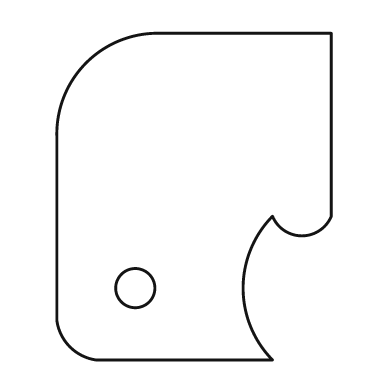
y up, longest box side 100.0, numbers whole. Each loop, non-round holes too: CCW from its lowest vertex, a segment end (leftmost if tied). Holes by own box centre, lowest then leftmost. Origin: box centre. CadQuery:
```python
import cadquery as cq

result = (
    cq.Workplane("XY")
    .moveTo(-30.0, -50.0)
    .lineTo(24.0, -50.0)
    .threePointArc((15.0, -28.0), (24.0, -6.0))
    .threePointArc((33.0, -12.0), (42.0, -6.0))
    .lineTo(42.0, 50.0)
    .lineTo(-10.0, 50.0)
    .threePointArc((-33.0, 41.0), (-42.0, 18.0))
    .lineTo(-42.0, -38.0)
    .threePointArc((-38.0, -46.0), (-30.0, -50.0))
    .close()
    .moveTo(-18.0, -28.0)
    .circle(6.0)
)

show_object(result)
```